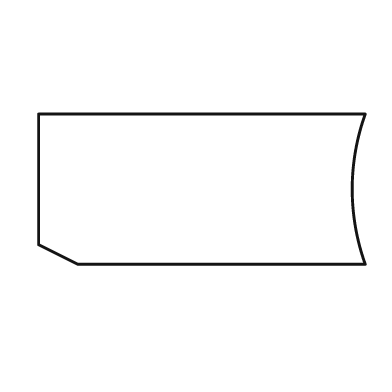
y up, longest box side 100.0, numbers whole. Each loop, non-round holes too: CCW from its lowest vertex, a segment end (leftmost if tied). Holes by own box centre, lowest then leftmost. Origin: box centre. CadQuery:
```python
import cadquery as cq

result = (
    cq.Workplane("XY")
    .moveTo(-38.0, -23.0)
    .lineTo(50.0, -23.0)
    .threePointArc((46.0, 0.0), (50.0, 23.0))
    .lineTo(-50.0, 23.0)
    .lineTo(-50.0, -17.0)
    .close()
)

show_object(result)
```